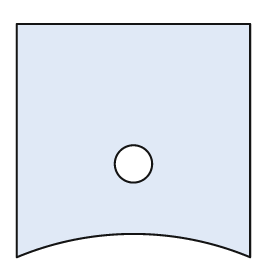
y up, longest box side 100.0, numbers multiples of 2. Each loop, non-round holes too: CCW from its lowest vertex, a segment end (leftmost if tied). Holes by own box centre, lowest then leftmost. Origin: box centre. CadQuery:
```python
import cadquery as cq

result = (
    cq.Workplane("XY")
    .moveTo(-50.0, -50.0)
    .threePointArc((0.0, -40.0), (50.0, -50.0))
    .lineTo(50.0, 50.0)
    .lineTo(-50.0, 50.0)
    .close()
    .moveTo(0.0, -10.0)
    .circle(8.0)
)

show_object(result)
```